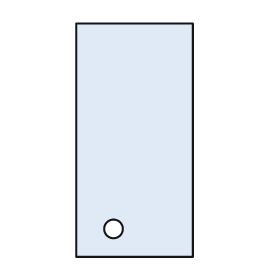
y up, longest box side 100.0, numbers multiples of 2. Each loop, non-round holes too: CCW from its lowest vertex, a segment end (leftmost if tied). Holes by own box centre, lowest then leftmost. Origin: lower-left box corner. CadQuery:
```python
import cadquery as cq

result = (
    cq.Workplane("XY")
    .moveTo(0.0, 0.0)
    .lineTo(50.0, 0.0)
    .lineTo(50.0, 100.0)
    .lineTo(0.0, 100.0)
    .close()
    .moveTo(16.0, 12.0)
    .circle(4.0)
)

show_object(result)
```